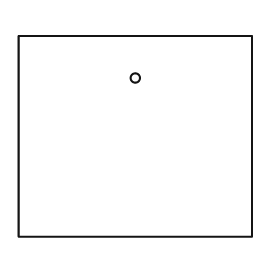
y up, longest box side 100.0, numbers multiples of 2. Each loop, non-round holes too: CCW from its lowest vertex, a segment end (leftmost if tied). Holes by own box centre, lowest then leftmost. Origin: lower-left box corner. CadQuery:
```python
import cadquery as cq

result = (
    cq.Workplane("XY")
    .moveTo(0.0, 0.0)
    .lineTo(100.0, 0.0)
    .lineTo(100.0, 86.0)
    .lineTo(0.0, 86.0)
    .close()
    .moveTo(50.0, 68.0)
    .circle(2.0)
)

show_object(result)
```